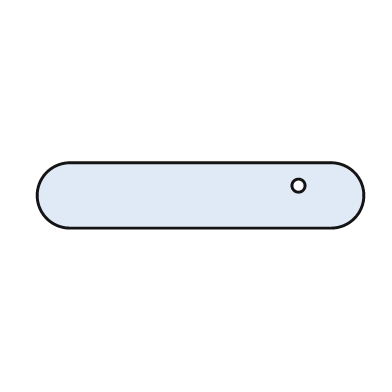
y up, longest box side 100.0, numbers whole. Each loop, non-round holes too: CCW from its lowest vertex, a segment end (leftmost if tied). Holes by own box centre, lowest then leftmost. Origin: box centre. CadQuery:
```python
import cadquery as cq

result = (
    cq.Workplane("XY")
    .moveTo(-40.0, -10.0)
    .lineTo(40.0, -10.0)
    .threePointArc((50.0, 0.0), (40.0, 10.0))
    .lineTo(-40.0, 10.0)
    .threePointArc((-50.0, 0.0), (-40.0, -10.0))
    .close()
    .moveTo(30.0, 3.0)
    .circle(2.0)
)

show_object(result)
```